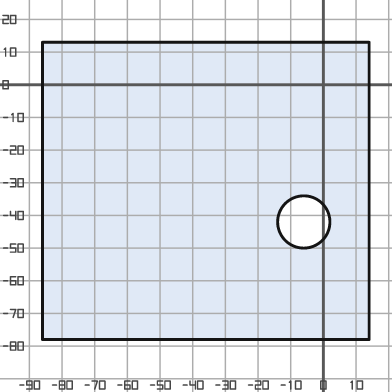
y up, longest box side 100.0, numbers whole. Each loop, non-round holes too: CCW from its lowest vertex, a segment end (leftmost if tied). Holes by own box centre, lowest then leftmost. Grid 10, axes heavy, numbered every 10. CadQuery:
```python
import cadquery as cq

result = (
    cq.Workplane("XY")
    .moveTo(-86.0, -78.0)
    .lineTo(14.0, -78.0)
    .lineTo(14.0, 13.0)
    .lineTo(-86.0, 13.0)
    .close()
    .moveTo(-6.0, -42.0)
    .circle(8.0)
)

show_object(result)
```